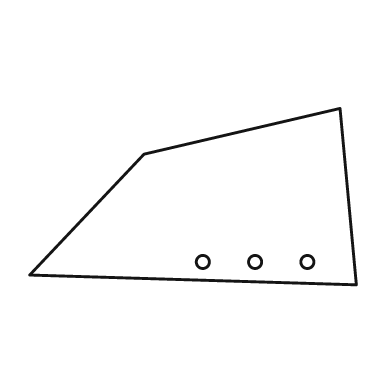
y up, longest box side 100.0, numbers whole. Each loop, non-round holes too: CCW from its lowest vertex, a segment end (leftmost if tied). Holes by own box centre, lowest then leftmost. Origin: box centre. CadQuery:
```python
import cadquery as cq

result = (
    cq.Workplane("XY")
    .moveTo(50.0, -27.0)
    .lineTo(45.0, 27.0)
    .lineTo(-15.0, 13.0)
    .lineTo(-50.0, -24.0)
    .close()
    .moveTo(3.0, -20.0)
    .circle(2.0)
    .moveTo(19.0, -20.0)
    .circle(2.0)
    .moveTo(35.0, -20.0)
    .circle(2.0)
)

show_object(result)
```